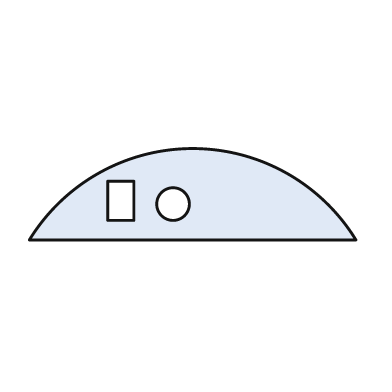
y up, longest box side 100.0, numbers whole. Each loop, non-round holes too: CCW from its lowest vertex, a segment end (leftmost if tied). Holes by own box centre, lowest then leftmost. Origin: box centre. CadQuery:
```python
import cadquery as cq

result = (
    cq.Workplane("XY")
    .moveTo(-50.0, -14.0)
    .lineTo(50.0, -14.0)
    .threePointArc((0.0, 14.0), (-50.0, -14.0))
    .close()
    .moveTo(-6.0, -3.0)
    .circle(5.0)
    .moveTo(-26.0, -8.0)
    .lineTo(-18.0, -8.0)
    .lineTo(-18.0, 4.0)
    .lineTo(-26.0, 4.0)
    .close()
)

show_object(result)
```